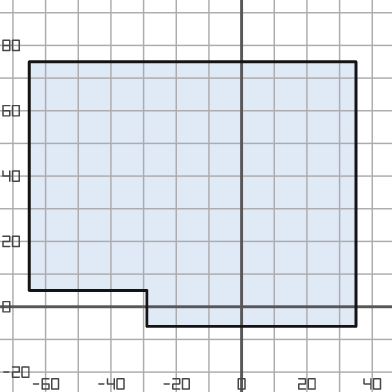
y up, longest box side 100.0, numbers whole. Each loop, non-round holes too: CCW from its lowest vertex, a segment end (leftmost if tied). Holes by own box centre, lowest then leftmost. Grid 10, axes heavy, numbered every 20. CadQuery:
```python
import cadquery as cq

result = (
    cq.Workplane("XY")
    .moveTo(-29.0, -6.0)
    .lineTo(35.0, -6.0)
    .lineTo(35.0, 75.0)
    .lineTo(-65.0, 75.0)
    .lineTo(-65.0, 5.0)
    .lineTo(-29.0, 5.0)
    .close()
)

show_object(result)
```